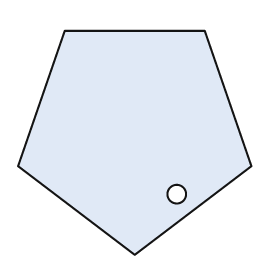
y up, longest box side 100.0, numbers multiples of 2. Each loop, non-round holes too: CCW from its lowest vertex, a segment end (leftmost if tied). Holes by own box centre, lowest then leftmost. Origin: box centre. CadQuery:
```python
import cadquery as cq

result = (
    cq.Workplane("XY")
    .moveTo(0.0, -48.0)
    .lineTo(50.0, -10.0)
    .lineTo(30.0, 48.0)
    .lineTo(-30.0, 48.0)
    .lineTo(-50.0, -10.0)
    .close()
    .moveTo(18.0, -22.0)
    .circle(4.0)
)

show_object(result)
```